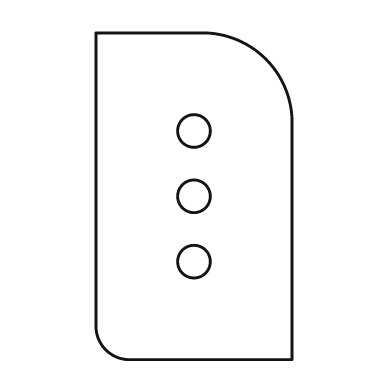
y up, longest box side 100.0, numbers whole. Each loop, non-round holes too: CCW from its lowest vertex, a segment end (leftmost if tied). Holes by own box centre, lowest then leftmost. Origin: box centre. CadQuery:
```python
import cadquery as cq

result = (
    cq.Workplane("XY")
    .moveTo(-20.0, -50.0)
    .lineTo(30.0, -50.0)
    .lineTo(30.0, 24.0)
    .threePointArc((22.0, 42.0), (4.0, 50.0))
    .lineTo(-30.0, 50.0)
    .lineTo(-30.0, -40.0)
    .threePointArc((-27.0, -47.0), (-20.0, -50.0))
    .close()
    .moveTo(0.0, -20.0)
    .circle(5.0)
    .moveTo(0.0, 0.0)
    .circle(5.0)
    .moveTo(0.0, 20.0)
    .circle(5.0)
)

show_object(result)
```